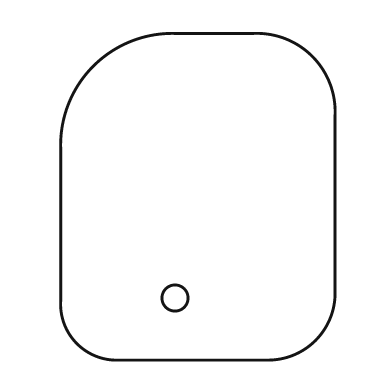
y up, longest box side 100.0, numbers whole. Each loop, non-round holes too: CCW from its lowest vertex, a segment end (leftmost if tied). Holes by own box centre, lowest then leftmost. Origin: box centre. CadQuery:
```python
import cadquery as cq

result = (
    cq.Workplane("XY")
    .moveTo(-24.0, -50.0)
    .lineTo(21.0, -50.0)
    .threePointArc((36.0, -44.0), (42.0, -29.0))
    .lineTo(42.0, 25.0)
    .threePointArc((35.0, 43.0), (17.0, 50.0))
    .lineTo(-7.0, 50.0)
    .threePointArc((-32.0, 40.0), (-42.0, 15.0))
    .lineTo(-42.0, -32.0)
    .threePointArc((-37.0, -45.0), (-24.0, -50.0))
    .close()
    .moveTo(-7.0, -31.0)
    .circle(4.0)
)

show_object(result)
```